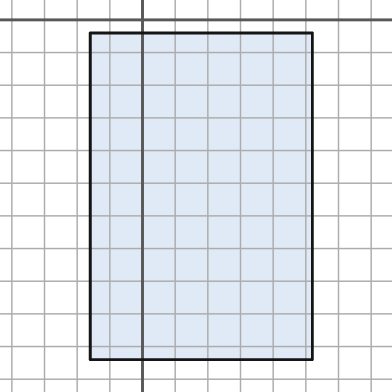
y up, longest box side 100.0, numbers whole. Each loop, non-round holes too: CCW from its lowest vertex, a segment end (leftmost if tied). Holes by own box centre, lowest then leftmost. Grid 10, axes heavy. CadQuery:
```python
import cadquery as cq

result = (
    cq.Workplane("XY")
    .moveTo(-16.0, -104.0)
    .lineTo(52.0, -104.0)
    .lineTo(52.0, -4.0)
    .lineTo(-16.0, -4.0)
    .close()
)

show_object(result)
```